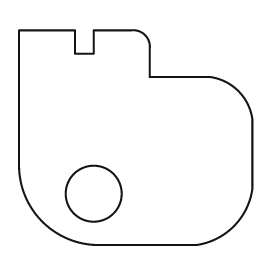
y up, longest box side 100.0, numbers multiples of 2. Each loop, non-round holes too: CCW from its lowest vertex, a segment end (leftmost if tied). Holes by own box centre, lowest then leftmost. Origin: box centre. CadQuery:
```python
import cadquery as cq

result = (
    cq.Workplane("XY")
    .moveTo(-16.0, -46.0)
    .lineTo(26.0, -46.0)
    .threePointArc((42.0, -38.0), (50.0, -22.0))
    .lineTo(50.0, 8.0)
    .threePointArc((44.0, 20.0), (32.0, 26.0))
    .lineTo(6.0, 26.0)
    .lineTo(6.0, 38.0)
    .threePointArc((4.0, 44.0), (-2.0, 46.0))
    .lineTo(-18.0, 46.0)
    .lineTo(-18.0, 36.0)
    .lineTo(-26.0, 36.0)
    .lineTo(-26.0, 46.0)
    .lineTo(-50.0, 46.0)
    .lineTo(-50.0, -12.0)
    .threePointArc((-40.0, -36.0), (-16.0, -46.0))
    .close()
    .moveTo(-18.0, -24.0)
    .circle(12.0)
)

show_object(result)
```